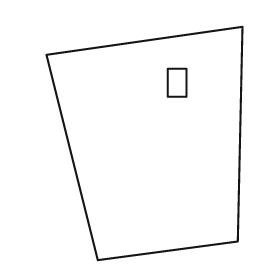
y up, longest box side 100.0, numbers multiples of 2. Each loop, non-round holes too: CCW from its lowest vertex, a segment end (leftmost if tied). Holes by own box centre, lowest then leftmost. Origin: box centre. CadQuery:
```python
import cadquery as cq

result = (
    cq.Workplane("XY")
    .moveTo(-20.0, -50.0)
    .lineTo(40.0, -42.0)
    .lineTo(42.0, 50.0)
    .lineTo(-42.0, 38.0)
    .close()
    .moveTo(10.0, 20.0)
    .lineTo(18.0, 20.0)
    .lineTo(18.0, 32.0)
    .lineTo(10.0, 32.0)
    .close()
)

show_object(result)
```